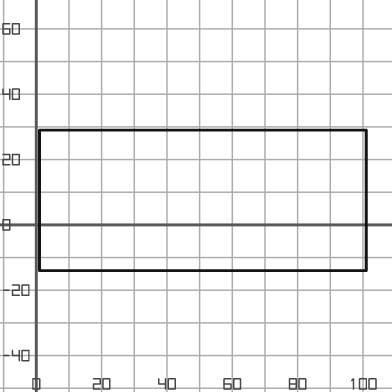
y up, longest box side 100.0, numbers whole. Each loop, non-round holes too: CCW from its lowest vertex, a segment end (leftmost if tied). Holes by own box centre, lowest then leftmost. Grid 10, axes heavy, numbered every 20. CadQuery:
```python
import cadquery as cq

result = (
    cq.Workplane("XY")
    .moveTo(1.0, -14.0)
    .lineTo(101.0, -14.0)
    .lineTo(101.0, 29.0)
    .lineTo(1.0, 29.0)
    .close()
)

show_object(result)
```